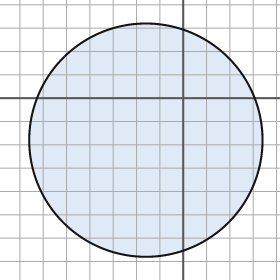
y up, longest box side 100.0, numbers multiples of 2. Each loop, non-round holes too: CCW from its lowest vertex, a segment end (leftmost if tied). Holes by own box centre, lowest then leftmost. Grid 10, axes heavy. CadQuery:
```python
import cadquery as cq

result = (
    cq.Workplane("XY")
    .moveTo(-16.0, -18.0)
    .circle(50.0)
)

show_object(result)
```